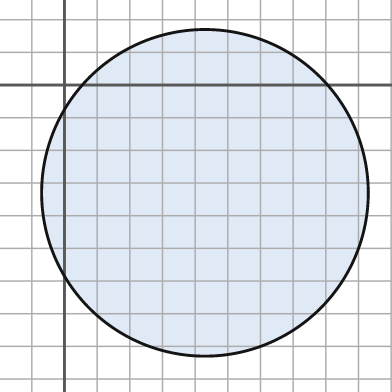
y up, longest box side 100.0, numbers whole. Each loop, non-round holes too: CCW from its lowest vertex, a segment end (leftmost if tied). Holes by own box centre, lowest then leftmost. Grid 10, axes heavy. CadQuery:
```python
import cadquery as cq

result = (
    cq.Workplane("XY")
    .moveTo(43.0, -33.0)
    .circle(50.0)
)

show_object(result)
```